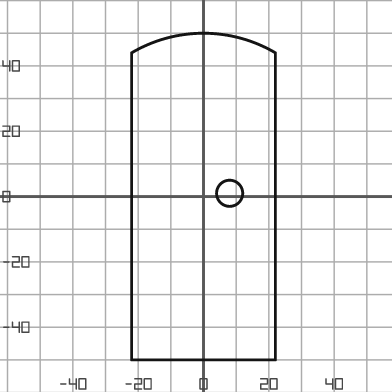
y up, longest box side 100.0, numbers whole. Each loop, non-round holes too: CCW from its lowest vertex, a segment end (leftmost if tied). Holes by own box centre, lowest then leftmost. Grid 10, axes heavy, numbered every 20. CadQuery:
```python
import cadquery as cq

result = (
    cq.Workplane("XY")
    .moveTo(-22.0, -50.0)
    .lineTo(22.0, -50.0)
    .lineTo(22.0, 44.0)
    .threePointArc((0.0, 50.0), (-22.0, 44.0))
    .close()
    .moveTo(8.0, 1.0)
    .circle(4.0)
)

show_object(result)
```